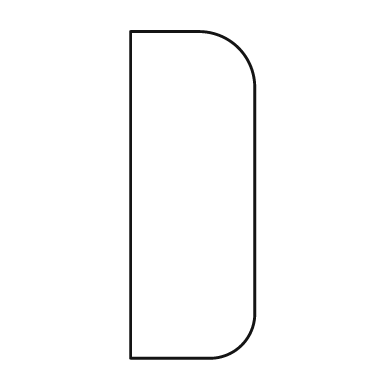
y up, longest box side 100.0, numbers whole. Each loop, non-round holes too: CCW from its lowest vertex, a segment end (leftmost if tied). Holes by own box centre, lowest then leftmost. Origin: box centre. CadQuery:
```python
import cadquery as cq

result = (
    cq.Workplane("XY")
    .moveTo(-19.0, -50.0)
    .lineTo(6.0, -50.0)
    .threePointArc((15.0, -46.0), (19.0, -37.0))
    .lineTo(19.0, 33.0)
    .threePointArc((14.0, 45.0), (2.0, 50.0))
    .lineTo(-19.0, 50.0)
    .close()
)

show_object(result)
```